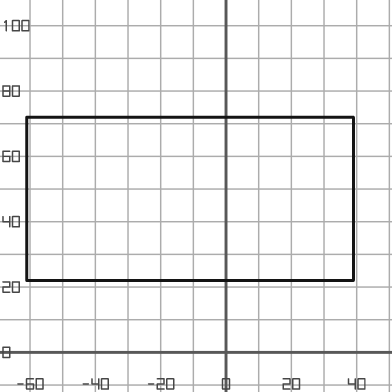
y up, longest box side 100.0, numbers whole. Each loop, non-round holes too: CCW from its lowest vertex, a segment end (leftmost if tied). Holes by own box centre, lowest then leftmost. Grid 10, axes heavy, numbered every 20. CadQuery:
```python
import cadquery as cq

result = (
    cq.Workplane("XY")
    .moveTo(-61.0, 22.0)
    .lineTo(39.0, 22.0)
    .lineTo(39.0, 72.0)
    .lineTo(-61.0, 72.0)
    .close()
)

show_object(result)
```